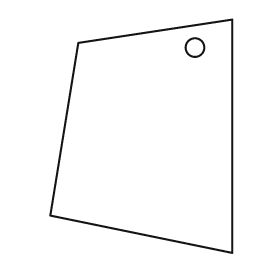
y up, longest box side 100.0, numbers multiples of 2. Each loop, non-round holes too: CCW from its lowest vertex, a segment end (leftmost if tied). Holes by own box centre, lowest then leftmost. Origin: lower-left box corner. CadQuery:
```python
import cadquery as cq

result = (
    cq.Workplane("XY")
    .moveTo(78.0, 0.0)
    .lineTo(78.0, 100.0)
    .lineTo(12.0, 90.0)
    .lineTo(0.0, 16.0)
    .close()
    .moveTo(62.0, 88.0)
    .circle(4.0)
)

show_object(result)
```